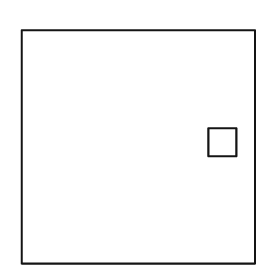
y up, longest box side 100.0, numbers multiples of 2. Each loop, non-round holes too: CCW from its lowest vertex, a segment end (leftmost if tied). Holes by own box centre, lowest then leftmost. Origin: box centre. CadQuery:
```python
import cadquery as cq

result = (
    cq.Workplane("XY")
    .moveTo(-50.0, -50.0)
    .lineTo(50.0, -50.0)
    .lineTo(50.0, 50.0)
    .lineTo(-50.0, 50.0)
    .close()
    .moveTo(30.0, -4.0)
    .lineTo(42.0, -4.0)
    .lineTo(42.0, 8.0)
    .lineTo(30.0, 8.0)
    .close()
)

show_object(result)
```